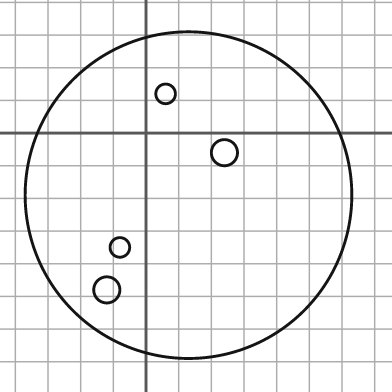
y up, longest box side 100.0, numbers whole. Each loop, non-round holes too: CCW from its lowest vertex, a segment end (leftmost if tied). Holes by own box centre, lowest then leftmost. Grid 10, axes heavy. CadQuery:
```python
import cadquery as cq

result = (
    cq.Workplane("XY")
    .moveTo(13.0, -19.0)
    .circle(50.0)
    .moveTo(-12.0, -48.0)
    .circle(4.0)
    .moveTo(-8.0, -35.0)
    .circle(3.0)
    .moveTo(24.0, -6.0)
    .circle(4.0)
    .moveTo(6.0, 12.0)
    .circle(3.0)
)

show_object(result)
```